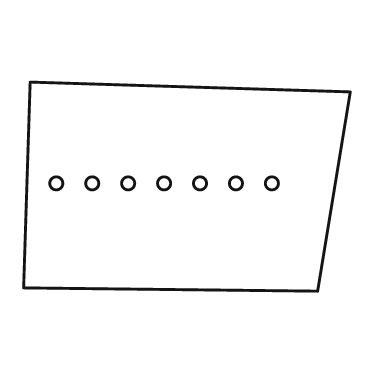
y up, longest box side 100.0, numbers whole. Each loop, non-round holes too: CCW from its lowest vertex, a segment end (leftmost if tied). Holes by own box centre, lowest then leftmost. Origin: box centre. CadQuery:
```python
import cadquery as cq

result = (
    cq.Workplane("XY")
    .moveTo(40.0, -32.0)
    .lineTo(50.0, 29.0)
    .lineTo(-48.0, 32.0)
    .lineTo(-50.0, -31.0)
    .close()
    .moveTo(-40.0, 1.0)
    .circle(2.0)
    .moveTo(-29.0, 1.0)
    .circle(2.0)
    .moveTo(-18.0, 1.0)
    .circle(2.0)
    .moveTo(-7.0, 1.0)
    .circle(2.0)
    .moveTo(4.0, 1.0)
    .circle(2.0)
    .moveTo(15.0, 1.0)
    .circle(2.0)
    .moveTo(26.0, 1.0)
    .circle(2.0)
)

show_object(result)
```